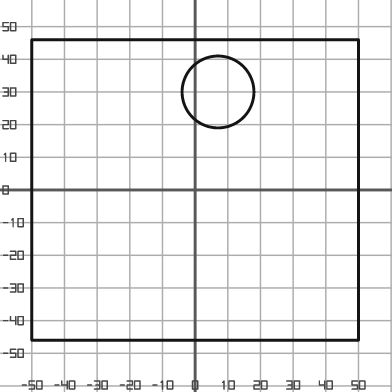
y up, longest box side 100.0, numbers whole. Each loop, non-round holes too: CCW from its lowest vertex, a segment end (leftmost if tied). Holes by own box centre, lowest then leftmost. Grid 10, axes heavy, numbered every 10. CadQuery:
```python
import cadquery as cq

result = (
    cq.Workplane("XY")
    .moveTo(-50.0, -46.0)
    .lineTo(50.0, -46.0)
    .lineTo(50.0, 46.0)
    .lineTo(-50.0, 46.0)
    .close()
    .moveTo(7.0, 30.0)
    .circle(11.0)
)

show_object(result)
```